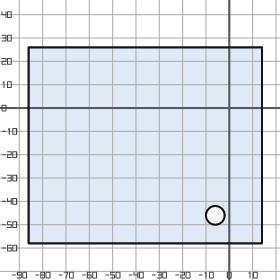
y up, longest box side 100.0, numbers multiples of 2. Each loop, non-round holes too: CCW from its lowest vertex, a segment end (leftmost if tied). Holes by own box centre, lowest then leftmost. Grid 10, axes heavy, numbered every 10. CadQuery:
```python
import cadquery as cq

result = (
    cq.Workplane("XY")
    .moveTo(-86.0, -58.0)
    .lineTo(14.0, -58.0)
    .lineTo(14.0, 26.0)
    .lineTo(-86.0, 26.0)
    .close()
    .moveTo(-6.0, -46.0)
    .circle(4.0)
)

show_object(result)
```